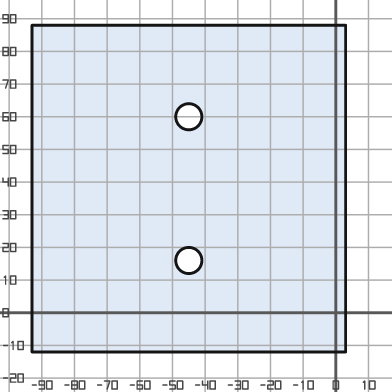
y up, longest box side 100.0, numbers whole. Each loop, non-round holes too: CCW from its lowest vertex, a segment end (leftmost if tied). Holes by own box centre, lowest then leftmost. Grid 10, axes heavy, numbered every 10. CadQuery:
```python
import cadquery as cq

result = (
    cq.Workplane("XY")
    .moveTo(-93.0, -12.0)
    .lineTo(3.0, -12.0)
    .lineTo(3.0, 88.0)
    .lineTo(-93.0, 88.0)
    .close()
    .moveTo(-45.0, 16.0)
    .circle(4.0)
    .moveTo(-45.0, 60.0)
    .circle(4.0)
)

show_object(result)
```